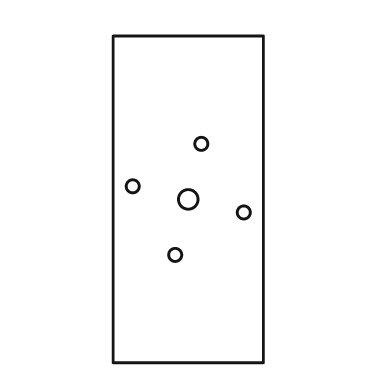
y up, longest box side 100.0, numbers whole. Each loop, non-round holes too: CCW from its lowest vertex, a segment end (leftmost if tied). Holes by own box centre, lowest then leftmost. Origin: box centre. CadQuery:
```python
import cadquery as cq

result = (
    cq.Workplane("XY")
    .moveTo(-23.0, -50.0)
    .lineTo(23.0, -50.0)
    .lineTo(23.0, 50.0)
    .lineTo(-23.0, 50.0)
    .close()
    .moveTo(-4.0, -17.0)
    .circle(2.0)
    .moveTo(17.0, -4.0)
    .circle(2.0)
    .moveTo(0.0, 0.0)
    .circle(3.0)
    .moveTo(-17.0, 4.0)
    .circle(2.0)
    .moveTo(4.0, 17.0)
    .circle(2.0)
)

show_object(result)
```